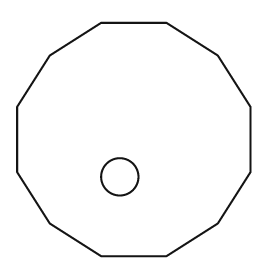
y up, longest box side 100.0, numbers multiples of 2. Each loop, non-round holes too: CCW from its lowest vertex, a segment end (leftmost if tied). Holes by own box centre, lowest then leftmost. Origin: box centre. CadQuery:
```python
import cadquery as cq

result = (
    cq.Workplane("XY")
    .moveTo(-14.0, -50.0)
    .lineTo(14.0, -50.0)
    .lineTo(36.0, -36.0)
    .lineTo(50.0, -14.0)
    .lineTo(50.0, 14.0)
    .lineTo(36.0, 36.0)
    .lineTo(14.0, 50.0)
    .lineTo(-14.0, 50.0)
    .lineTo(-36.0, 36.0)
    .lineTo(-50.0, 14.0)
    .lineTo(-50.0, -14.0)
    .lineTo(-36.0, -36.0)
    .close()
    .moveTo(-6.0, -16.0)
    .circle(8.0)
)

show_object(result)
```